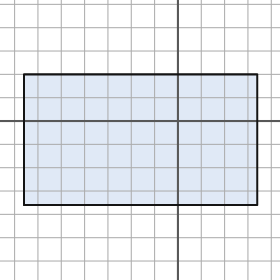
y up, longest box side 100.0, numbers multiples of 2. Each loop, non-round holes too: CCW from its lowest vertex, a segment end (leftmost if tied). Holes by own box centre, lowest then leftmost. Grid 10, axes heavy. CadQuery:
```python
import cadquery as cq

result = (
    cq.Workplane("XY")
    .moveTo(-66.0, -36.0)
    .lineTo(34.0, -36.0)
    .lineTo(34.0, 20.0)
    .lineTo(-66.0, 20.0)
    .close()
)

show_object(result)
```